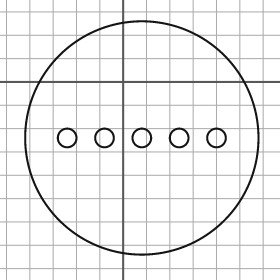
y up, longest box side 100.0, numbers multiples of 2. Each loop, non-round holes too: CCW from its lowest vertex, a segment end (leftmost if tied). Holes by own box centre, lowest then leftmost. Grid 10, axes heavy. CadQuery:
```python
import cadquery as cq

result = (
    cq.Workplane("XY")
    .moveTo(8.0, -24.0)
    .circle(50.0)
    .moveTo(-24.0, -24.0)
    .circle(4.0)
    .moveTo(-8.0, -24.0)
    .circle(4.0)
    .moveTo(8.0, -24.0)
    .circle(4.0)
    .moveTo(24.0, -24.0)
    .circle(4.0)
    .moveTo(40.0, -24.0)
    .circle(4.0)
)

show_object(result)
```